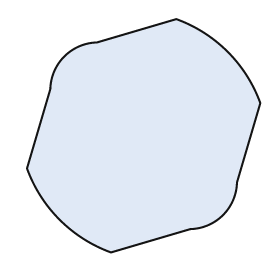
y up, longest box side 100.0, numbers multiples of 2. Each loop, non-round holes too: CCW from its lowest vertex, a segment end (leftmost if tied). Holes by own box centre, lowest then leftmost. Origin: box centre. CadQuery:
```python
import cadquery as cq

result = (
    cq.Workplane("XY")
    .moveTo(-14.0, -50.0)
    .lineTo(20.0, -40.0)
    .threePointArc((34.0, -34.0), (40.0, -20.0))
    .lineTo(50.0, 14.0)
    .threePointArc((36.0, 36.0), (14.0, 50.0))
    .lineTo(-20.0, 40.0)
    .threePointArc((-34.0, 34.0), (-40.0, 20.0))
    .lineTo(-50.0, -14.0)
    .threePointArc((-36.0, -36.0), (-14.0, -50.0))
    .close()
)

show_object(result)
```